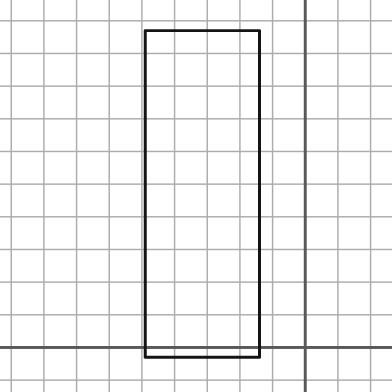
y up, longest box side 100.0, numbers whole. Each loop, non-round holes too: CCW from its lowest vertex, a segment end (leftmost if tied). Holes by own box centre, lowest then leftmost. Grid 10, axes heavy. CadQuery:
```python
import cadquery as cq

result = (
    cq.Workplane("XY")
    .moveTo(-49.0, -3.0)
    .lineTo(-14.0, -3.0)
    .lineTo(-14.0, 97.0)
    .lineTo(-49.0, 97.0)
    .close()
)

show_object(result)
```